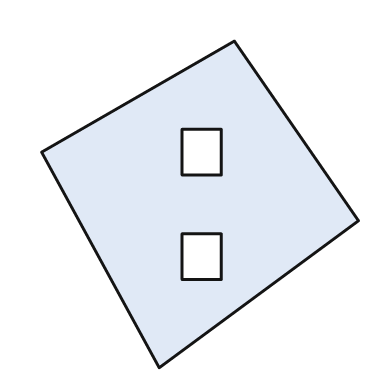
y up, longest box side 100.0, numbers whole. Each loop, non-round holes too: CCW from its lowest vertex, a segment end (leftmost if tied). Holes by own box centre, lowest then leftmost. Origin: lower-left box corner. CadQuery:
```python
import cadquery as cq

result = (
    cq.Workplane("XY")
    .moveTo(36.0, 0.0)
    .lineTo(97.0, 45.0)
    .lineTo(59.0, 100.0)
    .lineTo(0.0, 66.0)
    .close()
    .moveTo(43.0, 27.0)
    .lineTo(55.0, 27.0)
    .lineTo(55.0, 41.0)
    .lineTo(43.0, 41.0)
    .close()
    .moveTo(43.0, 59.0)
    .lineTo(55.0, 59.0)
    .lineTo(55.0, 73.0)
    .lineTo(43.0, 73.0)
    .close()
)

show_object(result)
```